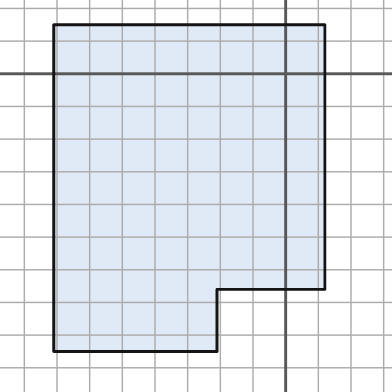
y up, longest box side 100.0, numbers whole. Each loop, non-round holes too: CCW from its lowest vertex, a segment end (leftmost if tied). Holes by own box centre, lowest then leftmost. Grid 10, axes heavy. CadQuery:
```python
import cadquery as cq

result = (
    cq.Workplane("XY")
    .moveTo(-71.0, -85.0)
    .lineTo(-21.0, -85.0)
    .lineTo(-21.0, -66.0)
    .lineTo(12.0, -66.0)
    .lineTo(12.0, 15.0)
    .lineTo(-71.0, 15.0)
    .close()
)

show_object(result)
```